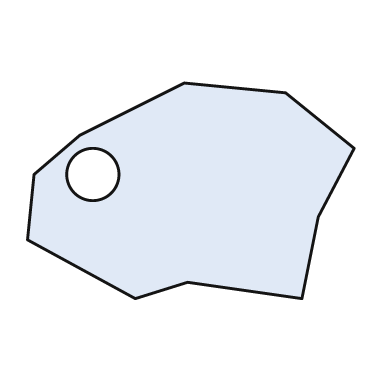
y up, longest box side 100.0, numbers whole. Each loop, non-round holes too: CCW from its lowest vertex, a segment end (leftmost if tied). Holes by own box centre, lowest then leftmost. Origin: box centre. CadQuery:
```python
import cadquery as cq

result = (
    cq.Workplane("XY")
    .moveTo(-17.0, -33.0)
    .lineTo(-1.0, -28.0)
    .lineTo(34.0, -33.0)
    .lineTo(39.0, -8.0)
    .lineTo(50.0, 13.0)
    .lineTo(29.0, 30.0)
    .lineTo(-2.0, 33.0)
    .lineTo(-34.0, 17.0)
    .lineTo(-48.0, 5.0)
    .lineTo(-50.0, -15.0)
    .close()
    .moveTo(-30.0, 5.0)
    .circle(8.0)
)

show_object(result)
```